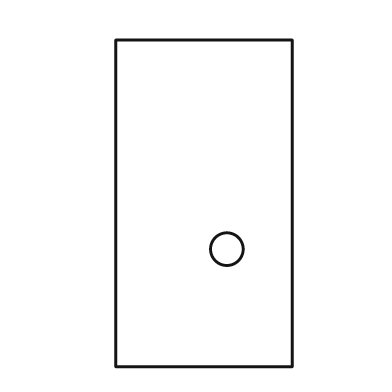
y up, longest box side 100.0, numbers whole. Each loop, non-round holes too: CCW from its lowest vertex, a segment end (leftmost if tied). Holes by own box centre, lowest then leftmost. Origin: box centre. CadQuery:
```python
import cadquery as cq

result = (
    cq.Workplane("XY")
    .moveTo(-27.0, -50.0)
    .lineTo(27.0, -50.0)
    .lineTo(27.0, 50.0)
    .lineTo(-27.0, 50.0)
    .close()
    .moveTo(7.0, -14.0)
    .circle(5.0)
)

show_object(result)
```